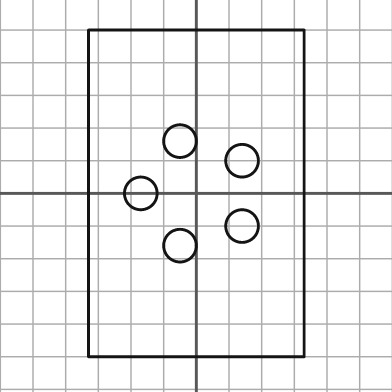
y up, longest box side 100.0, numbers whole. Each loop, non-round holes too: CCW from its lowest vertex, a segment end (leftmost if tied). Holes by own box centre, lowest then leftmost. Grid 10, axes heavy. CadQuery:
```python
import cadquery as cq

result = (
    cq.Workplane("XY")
    .moveTo(-33.0, -50.0)
    .lineTo(33.0, -50.0)
    .lineTo(33.0, 50.0)
    .lineTo(-33.0, 50.0)
    .close()
    .moveTo(-5.0, -16.0)
    .circle(5.0)
    .moveTo(14.0, -10.0)
    .circle(5.0)
    .moveTo(-17.0, 0.0)
    .circle(5.0)
    .moveTo(14.0, 10.0)
    .circle(5.0)
    .moveTo(-5.0, 16.0)
    .circle(5.0)
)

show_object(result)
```